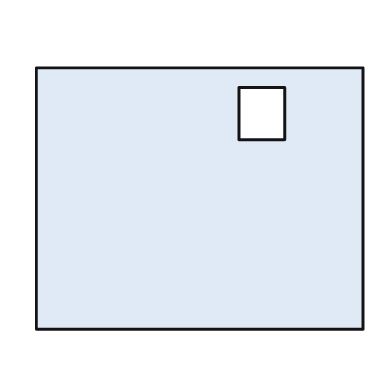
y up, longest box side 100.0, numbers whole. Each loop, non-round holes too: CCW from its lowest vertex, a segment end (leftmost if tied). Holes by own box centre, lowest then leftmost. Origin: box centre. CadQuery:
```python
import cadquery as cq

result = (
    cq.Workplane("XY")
    .moveTo(-50.0, -40.0)
    .lineTo(50.0, -40.0)
    .lineTo(50.0, 40.0)
    .lineTo(-50.0, 40.0)
    .close()
    .moveTo(12.0, 18.0)
    .lineTo(26.0, 18.0)
    .lineTo(26.0, 34.0)
    .lineTo(12.0, 34.0)
    .close()
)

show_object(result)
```